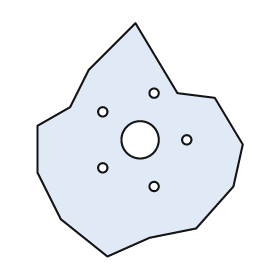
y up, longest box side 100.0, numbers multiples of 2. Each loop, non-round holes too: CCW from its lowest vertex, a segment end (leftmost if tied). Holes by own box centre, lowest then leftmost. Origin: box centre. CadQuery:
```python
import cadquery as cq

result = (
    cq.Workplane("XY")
    .moveTo(-14.0, -50.0)
    .lineTo(4.0, -42.0)
    .lineTo(24.0, -38.0)
    .lineTo(40.0, -20.0)
    .lineTo(44.0, -2.0)
    .lineTo(32.0, 18.0)
    .lineTo(16.0, 20.0)
    .lineTo(-2.0, 50.0)
    .lineTo(-22.0, 30.0)
    .lineTo(-30.0, 14.0)
    .lineTo(-44.0, 6.0)
    .lineTo(-44.0, -14.0)
    .lineTo(-34.0, -34.0)
    .close()
    .moveTo(6.0, -20.0)
    .circle(2.0)
    .moveTo(-16.0, -12.0)
    .circle(2.0)
    .moveTo(0.0, 0.0)
    .circle(8.0)
    .moveTo(20.0, 0.0)
    .circle(2.0)
    .moveTo(-16.0, 12.0)
    .circle(2.0)
    .moveTo(6.0, 20.0)
    .circle(2.0)
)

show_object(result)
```